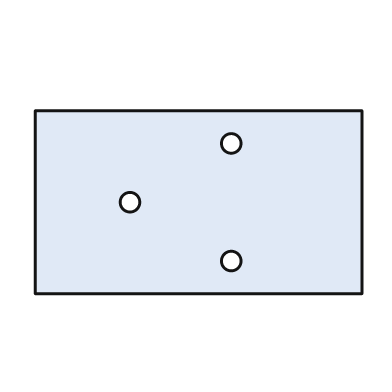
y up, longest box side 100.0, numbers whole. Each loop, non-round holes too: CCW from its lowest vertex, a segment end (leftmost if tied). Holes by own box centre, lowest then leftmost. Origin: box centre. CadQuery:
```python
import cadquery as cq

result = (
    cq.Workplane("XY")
    .moveTo(-50.0, -28.0)
    .lineTo(50.0, -28.0)
    .lineTo(50.0, 28.0)
    .lineTo(-50.0, 28.0)
    .close()
    .moveTo(10.0, -18.0)
    .circle(3.0)
    .moveTo(-21.0, 0.0)
    .circle(3.0)
    .moveTo(10.0, 18.0)
    .circle(3.0)
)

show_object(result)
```